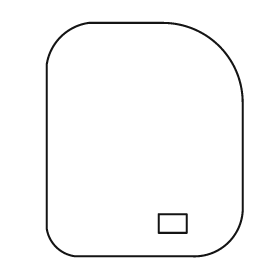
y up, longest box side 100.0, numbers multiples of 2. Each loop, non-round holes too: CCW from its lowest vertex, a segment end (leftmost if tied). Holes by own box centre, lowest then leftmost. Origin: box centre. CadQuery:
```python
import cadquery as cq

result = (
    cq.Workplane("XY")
    .moveTo(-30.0, -50.0)
    .lineTo(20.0, -50.0)
    .threePointArc((36.0, -44.0), (42.0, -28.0))
    .lineTo(42.0, 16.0)
    .threePointArc((32.0, 40.0), (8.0, 50.0))
    .lineTo(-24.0, 50.0)
    .threePointArc((-36.0, 44.0), (-42.0, 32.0))
    .lineTo(-42.0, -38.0)
    .threePointArc((-38.0, -46.0), (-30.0, -50.0))
    .close()
    .moveTo(6.0, -40.0)
    .lineTo(18.0, -40.0)
    .lineTo(18.0, -32.0)
    .lineTo(6.0, -32.0)
    .close()
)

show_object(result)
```